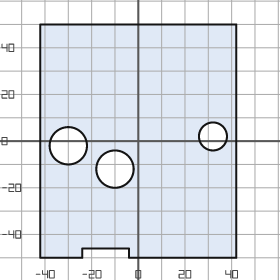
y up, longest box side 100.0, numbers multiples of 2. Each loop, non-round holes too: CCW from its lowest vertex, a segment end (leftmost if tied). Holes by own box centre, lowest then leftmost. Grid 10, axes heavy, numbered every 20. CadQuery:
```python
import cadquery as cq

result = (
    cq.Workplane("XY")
    .moveTo(-42.0, -50.0)
    .lineTo(-24.0, -50.0)
    .lineTo(-24.0, -46.0)
    .lineTo(-4.0, -46.0)
    .lineTo(-4.0, -50.0)
    .lineTo(42.0, -50.0)
    .lineTo(42.0, 50.0)
    .lineTo(-42.0, 50.0)
    .close()
    .moveTo(-10.0, -12.0)
    .circle(8.0)
    .moveTo(-30.0, -2.0)
    .circle(8.0)
    .moveTo(32.0, 2.0)
    .circle(6.0)
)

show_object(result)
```